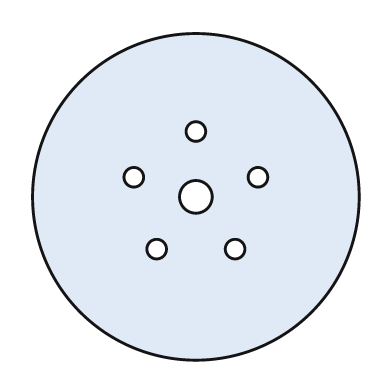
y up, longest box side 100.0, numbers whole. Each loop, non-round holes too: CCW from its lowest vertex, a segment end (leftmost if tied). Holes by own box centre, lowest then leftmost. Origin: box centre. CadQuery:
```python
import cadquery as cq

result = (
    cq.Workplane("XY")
    .moveTo(0.0, 0.0)
    .circle(50.0)
    .moveTo(-12.0, -16.0)
    .circle(3.0)
    .moveTo(12.0, -16.0)
    .circle(3.0)
    .moveTo(0.0, 0.0)
    .circle(5.0)
    .moveTo(-19.0, 6.0)
    .circle(3.0)
    .moveTo(19.0, 6.0)
    .circle(3.0)
    .moveTo(0.0, 20.0)
    .circle(3.0)
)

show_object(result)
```